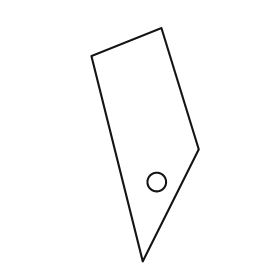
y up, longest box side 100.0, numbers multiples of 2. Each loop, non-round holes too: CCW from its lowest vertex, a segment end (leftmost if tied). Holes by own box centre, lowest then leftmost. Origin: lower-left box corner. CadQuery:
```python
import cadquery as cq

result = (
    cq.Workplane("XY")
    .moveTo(22.0, 0.0)
    .lineTo(46.0, 48.0)
    .lineTo(30.0, 100.0)
    .lineTo(0.0, 88.0)
    .close()
    .moveTo(28.0, 34.0)
    .circle(4.0)
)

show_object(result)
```